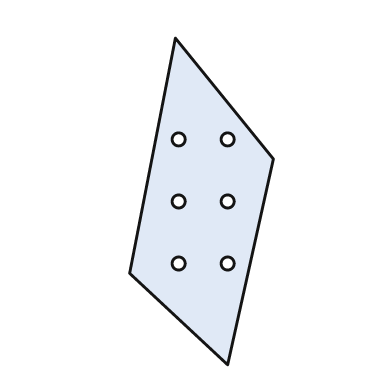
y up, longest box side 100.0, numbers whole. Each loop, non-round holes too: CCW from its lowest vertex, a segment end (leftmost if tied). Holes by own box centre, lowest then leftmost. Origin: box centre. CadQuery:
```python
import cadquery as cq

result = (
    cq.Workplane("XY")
    .moveTo(8.0, -50.0)
    .lineTo(22.0, 13.0)
    .lineTo(-8.0, 50.0)
    .lineTo(-22.0, -22.0)
    .close()
    .moveTo(-7.0, -19.0)
    .circle(2.0)
    .moveTo(8.0, -19.0)
    .circle(2.0)
    .moveTo(-7.0, 0.0)
    .circle(2.0)
    .moveTo(8.0, 0.0)
    .circle(2.0)
    .moveTo(-7.0, 19.0)
    .circle(2.0)
    .moveTo(8.0, 19.0)
    .circle(2.0)
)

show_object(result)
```